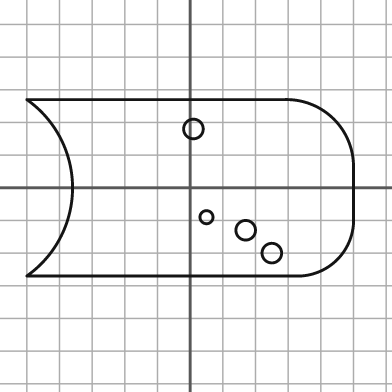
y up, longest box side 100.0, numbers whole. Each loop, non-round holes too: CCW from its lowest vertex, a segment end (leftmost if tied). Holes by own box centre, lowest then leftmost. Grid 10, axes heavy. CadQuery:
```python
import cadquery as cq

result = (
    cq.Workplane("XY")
    .moveTo(-50.0, -27.0)
    .lineTo(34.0, -27.0)
    .threePointArc((45.0, -22.0), (50.0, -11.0))
    .lineTo(50.0, 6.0)
    .threePointArc((44.0, 21.0), (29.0, 27.0))
    .lineTo(-50.0, 27.0)
    .threePointArc((-36.0, 0.0), (-50.0, -27.0))
    .close()
    .moveTo(25.0, -20.0)
    .circle(3.0)
    .moveTo(17.0, -13.0)
    .circle(3.0)
    .moveTo(5.0, -9.0)
    .circle(2.0)
    .moveTo(1.0, 18.0)
    .circle(3.0)
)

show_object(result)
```